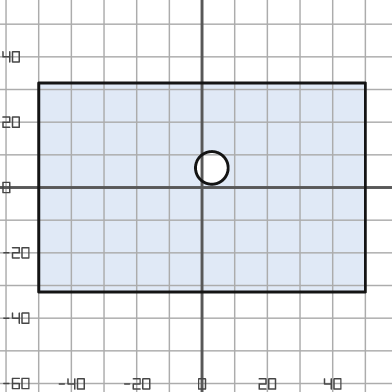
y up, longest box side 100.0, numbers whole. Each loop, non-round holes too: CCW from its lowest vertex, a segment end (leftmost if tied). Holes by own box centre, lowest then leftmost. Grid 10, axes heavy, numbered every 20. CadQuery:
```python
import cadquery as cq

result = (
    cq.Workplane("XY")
    .moveTo(-50.0, -32.0)
    .lineTo(50.0, -32.0)
    .lineTo(50.0, 32.0)
    .lineTo(-50.0, 32.0)
    .close()
    .moveTo(3.0, 6.0)
    .circle(5.0)
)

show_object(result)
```